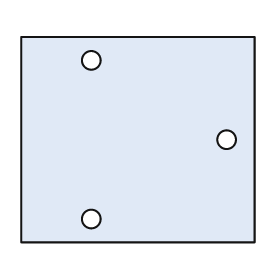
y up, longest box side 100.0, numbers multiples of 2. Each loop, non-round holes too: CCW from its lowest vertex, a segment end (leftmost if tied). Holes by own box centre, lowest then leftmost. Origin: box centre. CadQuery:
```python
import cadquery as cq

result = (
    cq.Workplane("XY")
    .moveTo(-50.0, -44.0)
    .lineTo(50.0, -44.0)
    .lineTo(50.0, 44.0)
    .lineTo(-50.0, 44.0)
    .close()
    .moveTo(-20.0, -34.0)
    .circle(4.0)
    .moveTo(38.0, 0.0)
    .circle(4.0)
    .moveTo(-20.0, 34.0)
    .circle(4.0)
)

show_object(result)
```